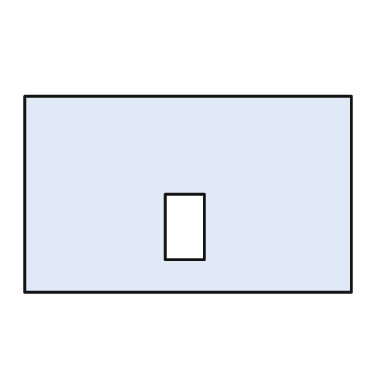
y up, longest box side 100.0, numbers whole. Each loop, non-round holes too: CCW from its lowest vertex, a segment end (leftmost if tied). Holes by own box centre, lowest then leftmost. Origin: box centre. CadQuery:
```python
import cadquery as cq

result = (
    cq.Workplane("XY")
    .moveTo(-50.0, -30.0)
    .lineTo(50.0, -30.0)
    .lineTo(50.0, 30.0)
    .lineTo(-50.0, 30.0)
    .close()
    .moveTo(-7.0, -20.0)
    .lineTo(5.0, -20.0)
    .lineTo(5.0, 0.0)
    .lineTo(-7.0, 0.0)
    .close()
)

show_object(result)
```